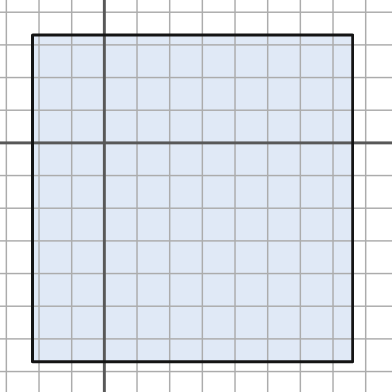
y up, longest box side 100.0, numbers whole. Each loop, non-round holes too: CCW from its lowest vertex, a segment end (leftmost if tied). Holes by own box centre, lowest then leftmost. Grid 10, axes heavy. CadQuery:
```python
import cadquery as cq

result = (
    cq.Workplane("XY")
    .moveTo(-22.0, -67.0)
    .lineTo(76.0, -67.0)
    .lineTo(76.0, 33.0)
    .lineTo(-22.0, 33.0)
    .close()
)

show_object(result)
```